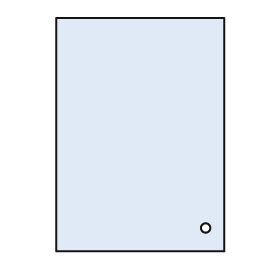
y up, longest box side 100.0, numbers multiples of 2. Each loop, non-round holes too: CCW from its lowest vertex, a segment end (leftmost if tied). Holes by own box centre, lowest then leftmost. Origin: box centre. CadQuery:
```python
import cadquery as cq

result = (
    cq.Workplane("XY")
    .moveTo(-36.0, -50.0)
    .lineTo(36.0, -50.0)
    .lineTo(36.0, 50.0)
    .lineTo(-36.0, 50.0)
    .close()
    .moveTo(28.0, -40.0)
    .circle(2.0)
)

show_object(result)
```